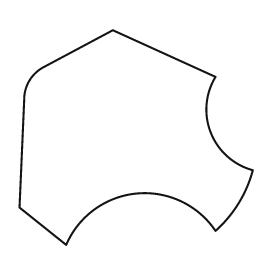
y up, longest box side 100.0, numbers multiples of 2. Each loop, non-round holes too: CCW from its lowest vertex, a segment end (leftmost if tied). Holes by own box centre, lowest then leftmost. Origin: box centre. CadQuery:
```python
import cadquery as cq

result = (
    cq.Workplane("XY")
    .moveTo(-30.0, -46.0)
    .threePointArc((0.0, -24.0), (34.0, -40.0))
    .threePointArc((44.0, -28.0), (50.0, -14.0))
    .threePointArc((32.0, 2.0), (34.0, 26.0))
    .lineTo(-10.0, 46.0)
    .lineTo(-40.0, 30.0)
    .threePointArc((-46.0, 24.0), (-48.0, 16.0))
    .lineTo(-50.0, -30.0)
    .close()
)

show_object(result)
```